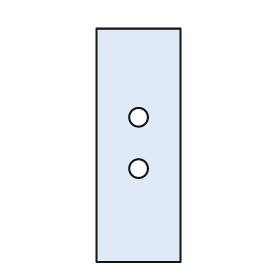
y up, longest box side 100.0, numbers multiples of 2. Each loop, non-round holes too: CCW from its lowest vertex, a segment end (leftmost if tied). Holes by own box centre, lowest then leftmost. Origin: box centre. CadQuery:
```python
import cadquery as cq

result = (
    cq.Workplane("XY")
    .moveTo(-18.0, -50.0)
    .lineTo(18.0, -50.0)
    .lineTo(18.0, 50.0)
    .lineTo(-18.0, 50.0)
    .close()
    .moveTo(0.0, -10.0)
    .circle(4.0)
    .moveTo(0.0, 12.0)
    .circle(4.0)
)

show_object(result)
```